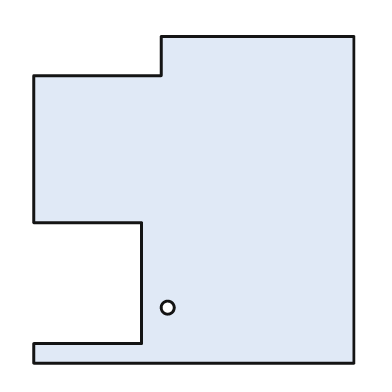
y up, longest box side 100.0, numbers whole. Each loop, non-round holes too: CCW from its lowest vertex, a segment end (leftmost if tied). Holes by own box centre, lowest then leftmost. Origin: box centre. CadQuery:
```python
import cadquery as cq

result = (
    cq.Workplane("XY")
    .moveTo(-49.0, -50.0)
    .lineTo(49.0, -50.0)
    .lineTo(49.0, 50.0)
    .lineTo(-10.0, 50.0)
    .lineTo(-10.0, 38.0)
    .lineTo(-49.0, 38.0)
    .lineTo(-49.0, -7.0)
    .lineTo(-16.0, -7.0)
    .lineTo(-16.0, -44.0)
    .lineTo(-49.0, -44.0)
    .close()
    .moveTo(-8.0, -33.0)
    .circle(2.0)
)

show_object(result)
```